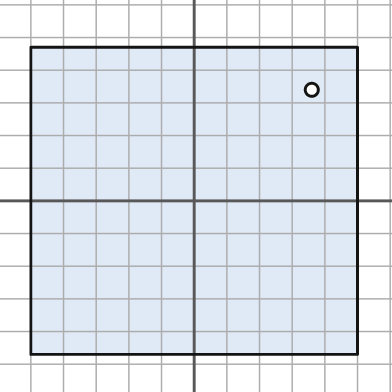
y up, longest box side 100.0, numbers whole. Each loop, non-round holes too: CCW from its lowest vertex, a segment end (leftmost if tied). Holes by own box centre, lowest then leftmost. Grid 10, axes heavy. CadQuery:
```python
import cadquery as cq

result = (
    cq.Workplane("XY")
    .moveTo(-50.0, -47.0)
    .lineTo(50.0, -47.0)
    .lineTo(50.0, 47.0)
    .lineTo(-50.0, 47.0)
    .close()
    .moveTo(36.0, 34.0)
    .circle(2.0)
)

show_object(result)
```